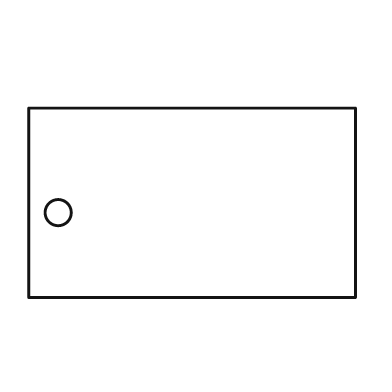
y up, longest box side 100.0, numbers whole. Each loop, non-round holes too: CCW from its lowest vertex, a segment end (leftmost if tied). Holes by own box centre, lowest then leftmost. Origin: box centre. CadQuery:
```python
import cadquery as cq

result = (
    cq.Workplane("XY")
    .moveTo(-50.0, -29.0)
    .lineTo(50.0, -29.0)
    .lineTo(50.0, 29.0)
    .lineTo(-50.0, 29.0)
    .close()
    .moveTo(-41.0, -3.0)
    .circle(4.0)
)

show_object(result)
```